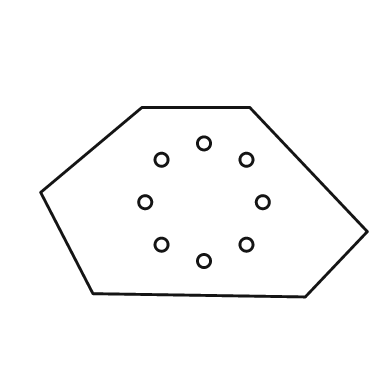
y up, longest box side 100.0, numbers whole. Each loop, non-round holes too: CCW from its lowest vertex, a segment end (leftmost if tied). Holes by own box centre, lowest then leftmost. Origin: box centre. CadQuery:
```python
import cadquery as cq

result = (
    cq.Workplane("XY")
    .moveTo(31.0, -29.0)
    .lineTo(50.0, -9.0)
    .lineTo(14.0, 29.0)
    .lineTo(-19.0, 29.0)
    .lineTo(-50.0, 3.0)
    .lineTo(-34.0, -28.0)
    .close()
    .moveTo(0.0, -18.0)
    .circle(2.0)
    .moveTo(-13.0, -13.0)
    .circle(2.0)
    .moveTo(13.0, -13.0)
    .circle(2.0)
    .moveTo(-18.0, 0.0)
    .circle(2.0)
    .moveTo(18.0, 0.0)
    .circle(2.0)
    .moveTo(-13.0, 13.0)
    .circle(2.0)
    .moveTo(13.0, 13.0)
    .circle(2.0)
    .moveTo(0.0, 18.0)
    .circle(2.0)
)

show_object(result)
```